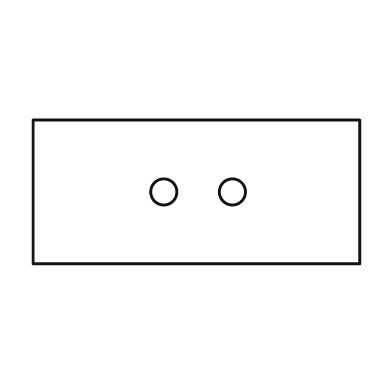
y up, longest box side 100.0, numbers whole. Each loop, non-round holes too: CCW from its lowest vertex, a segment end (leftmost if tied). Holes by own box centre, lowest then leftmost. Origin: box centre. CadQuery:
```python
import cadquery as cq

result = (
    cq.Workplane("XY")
    .moveTo(-50.0, -22.0)
    .lineTo(50.0, -22.0)
    .lineTo(50.0, 22.0)
    .lineTo(-50.0, 22.0)
    .close()
    .moveTo(-10.0, 0.0)
    .circle(4.0)
    .moveTo(11.0, 0.0)
    .circle(4.0)
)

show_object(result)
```